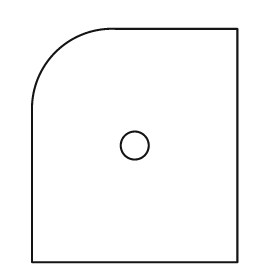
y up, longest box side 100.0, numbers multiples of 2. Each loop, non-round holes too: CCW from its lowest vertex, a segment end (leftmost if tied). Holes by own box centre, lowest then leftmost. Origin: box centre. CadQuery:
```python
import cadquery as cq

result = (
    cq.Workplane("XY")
    .moveTo(-44.0, -50.0)
    .lineTo(44.0, -50.0)
    .lineTo(44.0, 50.0)
    .lineTo(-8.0, 50.0)
    .threePointArc((-34.0, 40.0), (-44.0, 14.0))
    .close()
    .moveTo(0.0, 0.0)
    .circle(6.0)
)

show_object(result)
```